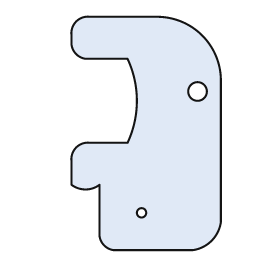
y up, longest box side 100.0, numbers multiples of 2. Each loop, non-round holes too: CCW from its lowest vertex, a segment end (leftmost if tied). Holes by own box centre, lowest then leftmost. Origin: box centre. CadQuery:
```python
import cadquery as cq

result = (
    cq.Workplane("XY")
    .moveTo(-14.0, -50.0)
    .lineTo(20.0, -50.0)
    .threePointArc((28.0, -46.0), (32.0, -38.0))
    .lineTo(32.0, 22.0)
    .threePointArc((24.0, 42.0), (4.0, 50.0))
    .lineTo(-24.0, 50.0)
    .threePointArc((-30.0, 48.0), (-32.0, 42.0))
    .lineTo(-32.0, 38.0)
    .threePointArc((-30.0, 34.0), (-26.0, 32.0))
    .lineTo(-8.0, 32.0)
    .threePointArc((-4.0, 14.0), (-8.0, -4.0))
    .lineTo(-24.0, -4.0)
    .threePointArc((-30.0, -6.0), (-32.0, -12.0))
    .lineTo(-32.0, -22.0)
    .threePointArc((-26.0, -24.0), (-20.0, -22.0))
    .lineTo(-20.0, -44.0)
    .threePointArc((-18.0, -48.0), (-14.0, -50.0))
    .close()
    .moveTo(-2.0, -34.0)
    .circle(2.0)
    .moveTo(22.0, 18.0)
    .circle(4.0)
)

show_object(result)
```